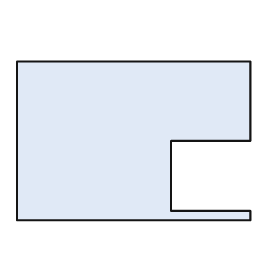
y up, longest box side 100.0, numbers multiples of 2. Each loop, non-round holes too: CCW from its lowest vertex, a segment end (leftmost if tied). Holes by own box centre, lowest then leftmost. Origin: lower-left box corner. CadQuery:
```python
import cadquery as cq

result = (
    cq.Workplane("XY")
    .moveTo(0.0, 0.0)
    .lineTo(100.0, 0.0)
    .lineTo(100.0, 4.0)
    .lineTo(66.0, 4.0)
    .lineTo(66.0, 34.0)
    .lineTo(100.0, 34.0)
    .lineTo(100.0, 68.0)
    .lineTo(0.0, 68.0)
    .close()
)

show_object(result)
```